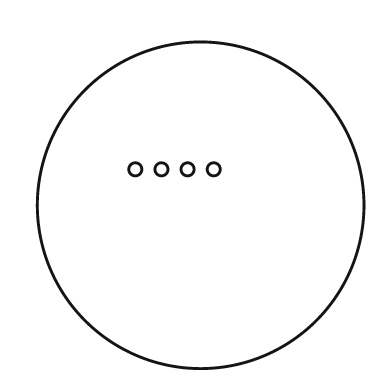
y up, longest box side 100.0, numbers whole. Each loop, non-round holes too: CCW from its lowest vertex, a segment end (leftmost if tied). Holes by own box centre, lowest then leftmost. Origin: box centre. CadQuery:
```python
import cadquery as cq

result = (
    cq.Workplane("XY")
    .moveTo(0.0, 0.0)
    .circle(50.0)
    .moveTo(-20.0, 11.0)
    .circle(2.0)
    .moveTo(-12.0, 11.0)
    .circle(2.0)
    .moveTo(-4.0, 11.0)
    .circle(2.0)
    .moveTo(4.0, 11.0)
    .circle(2.0)
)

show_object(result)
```